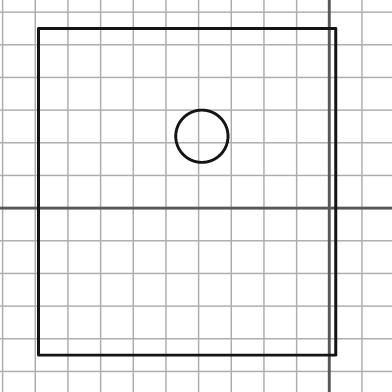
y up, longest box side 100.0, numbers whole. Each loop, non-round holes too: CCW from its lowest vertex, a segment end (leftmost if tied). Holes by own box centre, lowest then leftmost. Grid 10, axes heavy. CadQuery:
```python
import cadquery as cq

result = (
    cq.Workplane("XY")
    .moveTo(-89.0, -45.0)
    .lineTo(2.0, -45.0)
    .lineTo(2.0, 55.0)
    .lineTo(-89.0, 55.0)
    .close()
    .moveTo(-39.0, 22.0)
    .circle(8.0)
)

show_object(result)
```